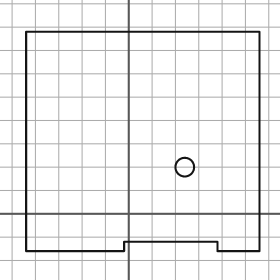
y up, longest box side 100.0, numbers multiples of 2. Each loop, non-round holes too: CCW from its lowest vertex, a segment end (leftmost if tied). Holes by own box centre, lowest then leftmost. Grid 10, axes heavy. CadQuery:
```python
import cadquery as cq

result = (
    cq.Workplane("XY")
    .moveTo(-44.0, -16.0)
    .lineTo(-2.0, -16.0)
    .lineTo(-2.0, -12.0)
    .lineTo(38.0, -12.0)
    .lineTo(38.0, -16.0)
    .lineTo(56.0, -16.0)
    .lineTo(56.0, 78.0)
    .lineTo(-44.0, 78.0)
    .close()
    .moveTo(24.0, 20.0)
    .circle(4.0)
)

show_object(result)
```